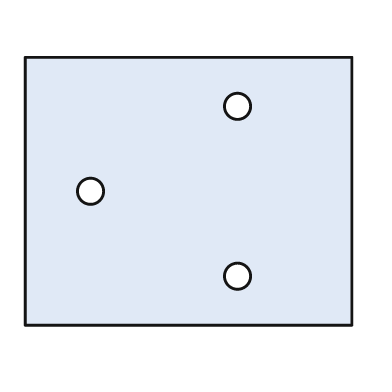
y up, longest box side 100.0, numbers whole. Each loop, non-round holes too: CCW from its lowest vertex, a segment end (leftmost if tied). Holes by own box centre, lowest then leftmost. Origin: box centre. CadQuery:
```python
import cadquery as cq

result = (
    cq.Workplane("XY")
    .moveTo(-50.0, -41.0)
    .lineTo(50.0, -41.0)
    .lineTo(50.0, 41.0)
    .lineTo(-50.0, 41.0)
    .close()
    .moveTo(15.0, -26.0)
    .circle(4.0)
    .moveTo(-30.0, 0.0)
    .circle(4.0)
    .moveTo(15.0, 26.0)
    .circle(4.0)
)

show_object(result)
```